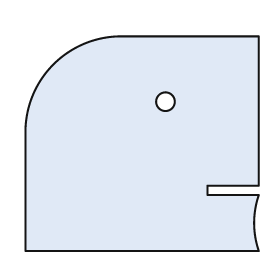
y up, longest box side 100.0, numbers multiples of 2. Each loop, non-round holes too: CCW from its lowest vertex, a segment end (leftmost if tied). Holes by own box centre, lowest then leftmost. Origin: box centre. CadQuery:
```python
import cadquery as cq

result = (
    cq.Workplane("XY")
    .moveTo(-50.0, -46.0)
    .lineTo(50.0, -46.0)
    .threePointArc((48.0, -34.0), (50.0, -22.0))
    .lineTo(28.0, -22.0)
    .lineTo(28.0, -18.0)
    .lineTo(50.0, -18.0)
    .lineTo(50.0, 46.0)
    .lineTo(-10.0, 46.0)
    .threePointArc((-38.0, 34.0), (-50.0, 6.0))
    .close()
    .moveTo(10.0, 18.0)
    .circle(4.0)
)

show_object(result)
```